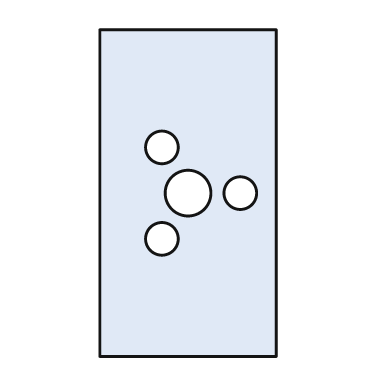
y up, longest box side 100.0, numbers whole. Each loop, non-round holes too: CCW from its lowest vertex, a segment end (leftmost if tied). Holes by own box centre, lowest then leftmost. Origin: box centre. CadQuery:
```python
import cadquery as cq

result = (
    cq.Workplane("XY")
    .moveTo(-27.0, -50.0)
    .lineTo(27.0, -50.0)
    .lineTo(27.0, 50.0)
    .lineTo(-27.0, 50.0)
    .close()
    .moveTo(-8.0, -14.0)
    .circle(5.0)
    .moveTo(0.0, 0.0)
    .circle(7.0)
    .moveTo(16.0, 0.0)
    .circle(5.0)
    .moveTo(-8.0, 14.0)
    .circle(5.0)
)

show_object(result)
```